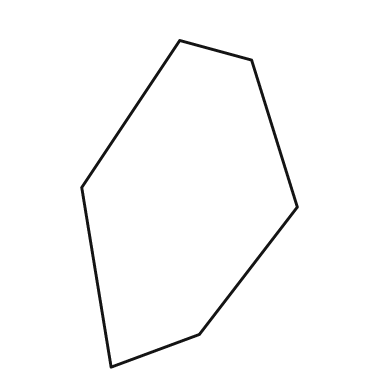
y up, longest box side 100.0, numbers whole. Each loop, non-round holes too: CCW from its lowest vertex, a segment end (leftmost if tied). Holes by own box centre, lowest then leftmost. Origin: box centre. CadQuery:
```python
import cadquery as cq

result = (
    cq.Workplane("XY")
    .moveTo(-24.0, -50.0)
    .lineTo(3.0, -40.0)
    .lineTo(33.0, -1.0)
    .lineTo(19.0, 44.0)
    .lineTo(-3.0, 50.0)
    .lineTo(-33.0, 5.0)
    .close()
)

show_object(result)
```